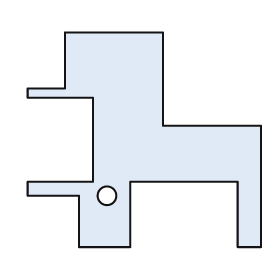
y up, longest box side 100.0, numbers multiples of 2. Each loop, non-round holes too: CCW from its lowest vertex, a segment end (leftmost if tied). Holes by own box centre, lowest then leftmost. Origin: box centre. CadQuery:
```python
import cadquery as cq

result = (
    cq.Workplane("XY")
    .moveTo(-28.0, -46.0)
    .lineTo(-6.0, -46.0)
    .lineTo(-6.0, -18.0)
    .lineTo(40.0, -18.0)
    .lineTo(40.0, -46.0)
    .lineTo(50.0, -46.0)
    .lineTo(50.0, 6.0)
    .lineTo(8.0, 6.0)
    .lineTo(8.0, 46.0)
    .lineTo(-34.0, 46.0)
    .lineTo(-34.0, 22.0)
    .lineTo(-50.0, 22.0)
    .lineTo(-50.0, 18.0)
    .lineTo(-22.0, 18.0)
    .lineTo(-22.0, -18.0)
    .lineTo(-50.0, -18.0)
    .lineTo(-50.0, -24.0)
    .lineTo(-28.0, -24.0)
    .close()
    .moveTo(-16.0, -24.0)
    .circle(4.0)
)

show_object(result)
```